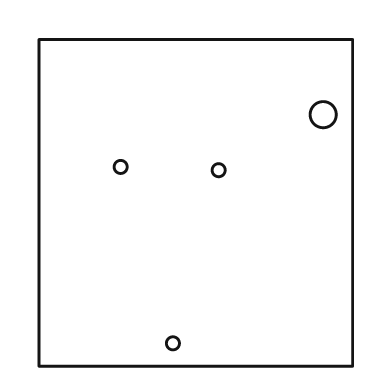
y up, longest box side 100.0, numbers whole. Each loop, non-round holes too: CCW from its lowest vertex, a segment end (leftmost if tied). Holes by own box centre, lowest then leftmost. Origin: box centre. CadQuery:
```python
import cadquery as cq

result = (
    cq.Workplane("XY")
    .moveTo(-48.0, -50.0)
    .lineTo(48.0, -50.0)
    .lineTo(48.0, 50.0)
    .lineTo(-48.0, 50.0)
    .close()
    .moveTo(-7.0, -43.0)
    .circle(2.0)
    .moveTo(7.0, 10.0)
    .circle(2.0)
    .moveTo(-23.0, 11.0)
    .circle(2.0)
    .moveTo(39.0, 27.0)
    .circle(4.0)
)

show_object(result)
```